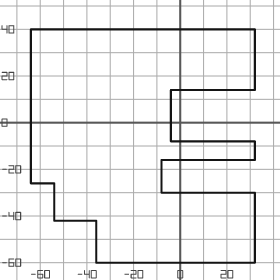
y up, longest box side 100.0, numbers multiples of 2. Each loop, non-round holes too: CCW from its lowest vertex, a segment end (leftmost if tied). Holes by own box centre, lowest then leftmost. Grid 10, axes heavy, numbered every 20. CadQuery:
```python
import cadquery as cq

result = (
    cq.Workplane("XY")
    .moveTo(-36.0, -60.0)
    .lineTo(32.0, -60.0)
    .lineTo(32.0, -30.0)
    .lineTo(-8.0, -30.0)
    .lineTo(-8.0, -16.0)
    .lineTo(32.0, -16.0)
    .lineTo(32.0, -8.0)
    .lineTo(-4.0, -8.0)
    .lineTo(-4.0, 14.0)
    .lineTo(32.0, 14.0)
    .lineTo(32.0, 40.0)
    .lineTo(-64.0, 40.0)
    .lineTo(-64.0, -26.0)
    .lineTo(-54.0, -26.0)
    .lineTo(-54.0, -42.0)
    .lineTo(-36.0, -42.0)
    .close()
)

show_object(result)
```